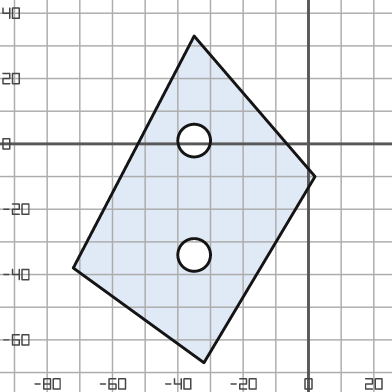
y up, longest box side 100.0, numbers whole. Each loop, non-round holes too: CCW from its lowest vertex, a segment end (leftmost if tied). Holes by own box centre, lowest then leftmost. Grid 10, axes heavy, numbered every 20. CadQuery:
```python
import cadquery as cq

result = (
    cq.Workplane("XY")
    .moveTo(-32.0, -67.0)
    .lineTo(2.0, -10.0)
    .lineTo(-35.0, 33.0)
    .lineTo(-72.0, -38.0)
    .close()
    .moveTo(-35.0, -34.0)
    .circle(5.0)
    .moveTo(-35.0, 1.0)
    .circle(5.0)
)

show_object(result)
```